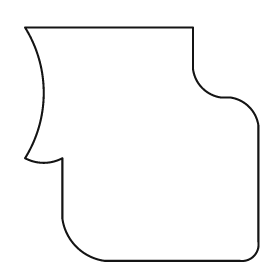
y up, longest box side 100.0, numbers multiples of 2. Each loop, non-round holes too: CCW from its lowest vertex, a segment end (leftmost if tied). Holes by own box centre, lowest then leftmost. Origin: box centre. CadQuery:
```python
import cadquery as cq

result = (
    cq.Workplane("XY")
    .moveTo(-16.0, -50.0)
    .lineTo(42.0, -50.0)
    .threePointArc((48.0, -48.0), (50.0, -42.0))
    .lineTo(50.0, 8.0)
    .threePointArc((46.0, 16.0), (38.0, 20.0))
    .lineTo(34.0, 20.0)
    .threePointArc((26.0, 24.0), (22.0, 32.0))
    .lineTo(22.0, 50.0)
    .lineTo(-50.0, 50.0)
    .threePointArc((-42.0, 22.0), (-50.0, -6.0))
    .threePointArc((-42.0, -8.0), (-34.0, -6.0))
    .lineTo(-34.0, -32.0)
    .threePointArc((-28.0, -44.0), (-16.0, -50.0))
    .close()
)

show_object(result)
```